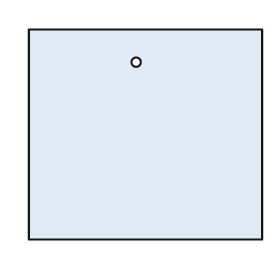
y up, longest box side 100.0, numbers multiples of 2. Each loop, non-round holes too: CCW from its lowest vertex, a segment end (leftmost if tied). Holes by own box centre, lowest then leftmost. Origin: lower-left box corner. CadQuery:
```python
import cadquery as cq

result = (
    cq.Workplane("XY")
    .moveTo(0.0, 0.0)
    .lineTo(100.0, 0.0)
    .lineTo(100.0, 90.0)
    .lineTo(0.0, 90.0)
    .close()
    .moveTo(46.0, 76.0)
    .circle(2.0)
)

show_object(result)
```